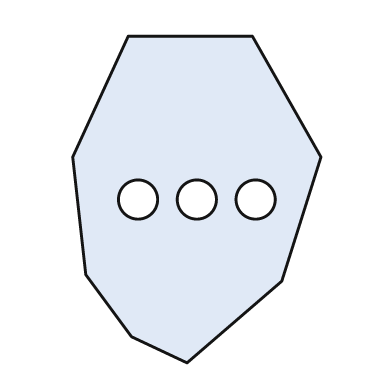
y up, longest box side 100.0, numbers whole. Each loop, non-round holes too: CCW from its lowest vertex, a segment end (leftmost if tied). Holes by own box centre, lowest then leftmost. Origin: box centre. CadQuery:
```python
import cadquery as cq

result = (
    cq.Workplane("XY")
    .moveTo(-3.0, -50.0)
    .lineTo(26.0, -25.0)
    .lineTo(38.0, 13.0)
    .lineTo(17.0, 50.0)
    .lineTo(-21.0, 50.0)
    .lineTo(-38.0, 13.0)
    .lineTo(-34.0, -23.0)
    .lineTo(-20.0, -42.0)
    .close()
    .moveTo(-18.0, 0.0)
    .circle(6.0)
    .moveTo(0.0, 0.0)
    .circle(6.0)
    .moveTo(18.0, 0.0)
    .circle(6.0)
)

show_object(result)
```